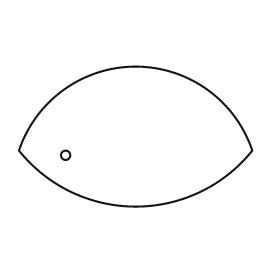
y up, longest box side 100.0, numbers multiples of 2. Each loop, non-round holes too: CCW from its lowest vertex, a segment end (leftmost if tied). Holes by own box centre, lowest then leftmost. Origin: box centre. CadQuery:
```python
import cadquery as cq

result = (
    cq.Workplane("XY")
    .moveTo(-50.0, -6.0)
    .threePointArc((0.0, -30.0), (50.0, -6.0))
    .threePointArc((0.0, 30.0), (-50.0, -6.0))
    .close()
    .moveTo(-30.0, -8.0)
    .circle(2.0)
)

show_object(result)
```